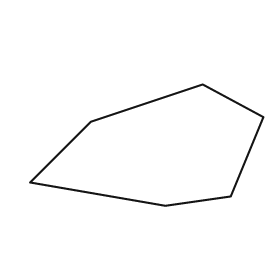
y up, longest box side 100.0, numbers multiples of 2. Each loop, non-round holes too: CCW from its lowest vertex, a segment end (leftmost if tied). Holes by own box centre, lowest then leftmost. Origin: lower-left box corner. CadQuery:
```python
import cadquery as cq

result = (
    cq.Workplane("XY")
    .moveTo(58.0, 0.0)
    .lineTo(86.0, 4.0)
    .lineTo(100.0, 38.0)
    .lineTo(74.0, 52.0)
    .lineTo(26.0, 36.0)
    .lineTo(0.0, 10.0)
    .close()
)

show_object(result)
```